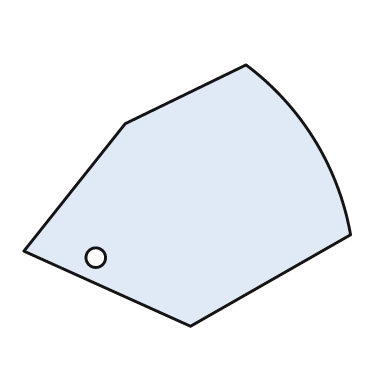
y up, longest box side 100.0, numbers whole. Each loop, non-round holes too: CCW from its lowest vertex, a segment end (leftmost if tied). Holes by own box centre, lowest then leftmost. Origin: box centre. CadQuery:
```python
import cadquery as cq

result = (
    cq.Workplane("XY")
    .moveTo(1.0, -40.0)
    .lineTo(50.0, -12.0)
    .threePointArc((39.0, 17.0), (18.0, 40.0))
    .lineTo(-19.0, 22.0)
    .lineTo(-50.0, -17.0)
    .close()
    .moveTo(-28.0, -19.0)
    .circle(3.0)
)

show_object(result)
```